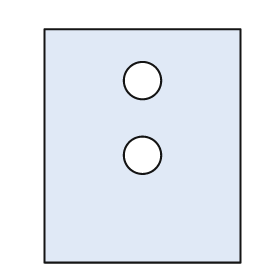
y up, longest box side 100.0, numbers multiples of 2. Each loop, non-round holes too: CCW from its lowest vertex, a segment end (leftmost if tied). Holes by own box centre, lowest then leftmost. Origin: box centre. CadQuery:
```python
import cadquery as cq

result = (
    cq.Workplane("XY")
    .moveTo(-42.0, -50.0)
    .lineTo(42.0, -50.0)
    .lineTo(42.0, 50.0)
    .lineTo(-42.0, 50.0)
    .close()
    .moveTo(0.0, -4.0)
    .circle(8.0)
    .moveTo(0.0, 28.0)
    .circle(8.0)
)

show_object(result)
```